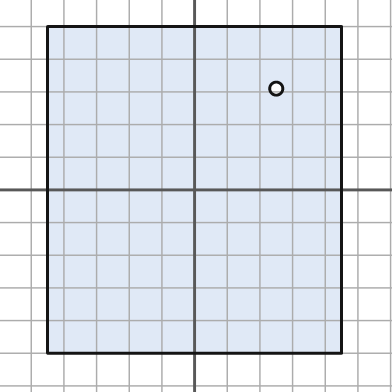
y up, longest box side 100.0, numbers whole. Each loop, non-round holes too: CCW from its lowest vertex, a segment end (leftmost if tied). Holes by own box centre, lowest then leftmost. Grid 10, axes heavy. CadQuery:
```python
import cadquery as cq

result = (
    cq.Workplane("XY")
    .moveTo(-45.0, -50.0)
    .lineTo(45.0, -50.0)
    .lineTo(45.0, 50.0)
    .lineTo(-45.0, 50.0)
    .close()
    .moveTo(25.0, 31.0)
    .circle(2.0)
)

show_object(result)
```